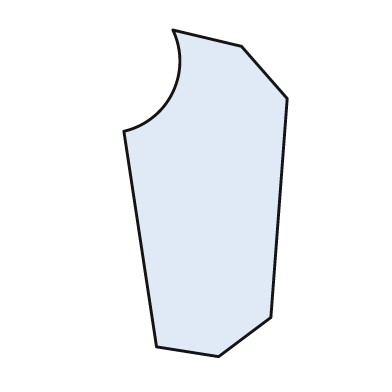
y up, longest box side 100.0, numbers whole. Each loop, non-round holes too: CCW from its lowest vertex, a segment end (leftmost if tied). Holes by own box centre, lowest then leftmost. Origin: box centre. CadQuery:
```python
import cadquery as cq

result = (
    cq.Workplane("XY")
    .moveTo(4.0, -50.0)
    .lineTo(20.0, -38.0)
    .lineTo(25.0, 29.0)
    .lineTo(11.0, 45.0)
    .lineTo(-10.0, 50.0)
    .threePointArc((-10.0, 31.0), (-25.0, 19.0))
    .lineTo(-15.0, -47.0)
    .close()
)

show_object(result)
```